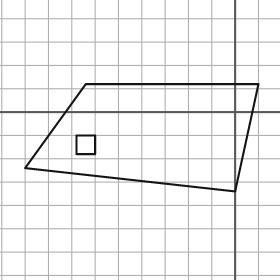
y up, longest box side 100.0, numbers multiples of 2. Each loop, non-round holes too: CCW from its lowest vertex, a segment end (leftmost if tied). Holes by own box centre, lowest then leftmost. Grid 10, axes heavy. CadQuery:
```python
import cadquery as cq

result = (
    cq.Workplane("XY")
    .moveTo(0.0, -34.0)
    .lineTo(10.0, 12.0)
    .lineTo(-64.0, 12.0)
    .lineTo(-90.0, -24.0)
    .close()
    .moveTo(-68.0, -18.0)
    .lineTo(-60.0, -18.0)
    .lineTo(-60.0, -10.0)
    .lineTo(-68.0, -10.0)
    .close()
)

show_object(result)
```